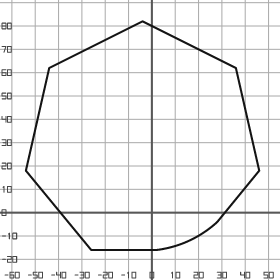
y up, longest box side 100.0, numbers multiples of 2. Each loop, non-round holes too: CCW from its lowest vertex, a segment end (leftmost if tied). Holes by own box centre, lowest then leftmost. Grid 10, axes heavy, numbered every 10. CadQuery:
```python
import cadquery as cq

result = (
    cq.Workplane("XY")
    .moveTo(-26.0, -16.0)
    .lineTo(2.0, -16.0)
    .threePointArc((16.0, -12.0), (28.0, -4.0))
    .lineTo(46.0, 18.0)
    .lineTo(36.0, 62.0)
    .lineTo(-4.0, 82.0)
    .lineTo(-44.0, 62.0)
    .lineTo(-54.0, 18.0)
    .close()
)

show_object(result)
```